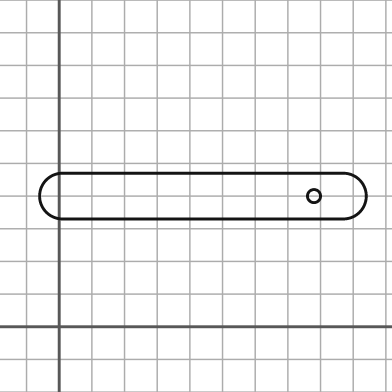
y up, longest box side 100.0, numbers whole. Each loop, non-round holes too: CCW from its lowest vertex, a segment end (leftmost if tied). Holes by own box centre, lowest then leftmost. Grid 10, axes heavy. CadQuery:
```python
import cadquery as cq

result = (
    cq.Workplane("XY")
    .moveTo(1.0, 33.0)
    .lineTo(87.0, 33.0)
    .threePointArc((94.0, 40.0), (87.0, 47.0))
    .lineTo(1.0, 47.0)
    .threePointArc((-6.0, 40.0), (1.0, 33.0))
    .close()
    .moveTo(78.0, 40.0)
    .circle(2.0)
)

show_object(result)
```